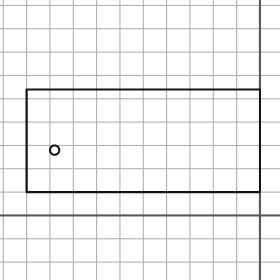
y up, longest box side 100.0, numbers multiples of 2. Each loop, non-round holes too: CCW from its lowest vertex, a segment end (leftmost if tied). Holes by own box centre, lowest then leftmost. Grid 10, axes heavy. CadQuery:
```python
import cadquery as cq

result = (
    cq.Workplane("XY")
    .moveTo(-100.0, 10.0)
    .lineTo(0.0, 10.0)
    .lineTo(0.0, 54.0)
    .lineTo(-100.0, 54.0)
    .close()
    .moveTo(-88.0, 28.0)
    .circle(2.0)
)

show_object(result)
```